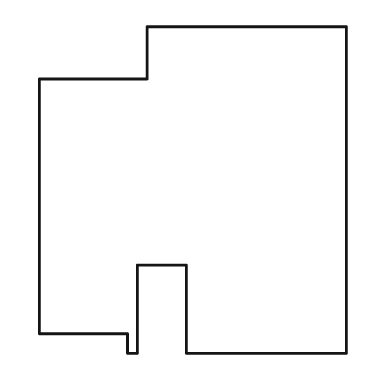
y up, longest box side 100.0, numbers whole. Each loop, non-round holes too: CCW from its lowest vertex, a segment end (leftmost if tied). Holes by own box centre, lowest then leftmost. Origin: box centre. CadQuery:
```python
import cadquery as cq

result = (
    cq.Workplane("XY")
    .moveTo(-20.0, -50.0)
    .lineTo(-17.0, -50.0)
    .lineTo(-17.0, -23.0)
    .lineTo(-2.0, -23.0)
    .lineTo(-2.0, -50.0)
    .lineTo(47.0, -50.0)
    .lineTo(47.0, 50.0)
    .lineTo(-14.0, 50.0)
    .lineTo(-14.0, 34.0)
    .lineTo(-47.0, 34.0)
    .lineTo(-47.0, -44.0)
    .lineTo(-20.0, -44.0)
    .close()
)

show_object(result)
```